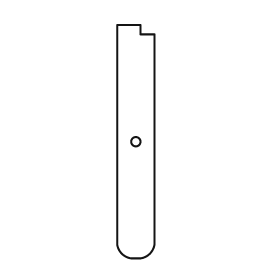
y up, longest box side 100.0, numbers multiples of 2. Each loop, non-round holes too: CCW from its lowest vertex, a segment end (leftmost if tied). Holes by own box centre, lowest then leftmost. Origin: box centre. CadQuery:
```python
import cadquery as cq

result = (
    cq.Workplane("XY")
    .moveTo(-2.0, -50.0)
    .lineTo(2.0, -50.0)
    .threePointArc((6.0, -48.0), (8.0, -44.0))
    .lineTo(8.0, 46.0)
    .lineTo(2.0, 46.0)
    .lineTo(2.0, 50.0)
    .lineTo(-8.0, 50.0)
    .lineTo(-8.0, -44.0)
    .threePointArc((-6.0, -48.0), (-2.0, -50.0))
    .close()
    .moveTo(0.0, 0.0)
    .circle(2.0)
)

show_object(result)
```